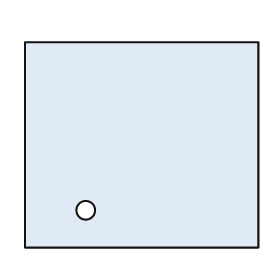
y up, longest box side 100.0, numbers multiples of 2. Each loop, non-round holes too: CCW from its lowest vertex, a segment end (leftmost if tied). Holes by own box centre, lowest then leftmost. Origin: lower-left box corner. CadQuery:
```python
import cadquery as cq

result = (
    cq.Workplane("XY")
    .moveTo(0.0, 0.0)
    .lineTo(100.0, 0.0)
    .lineTo(100.0, 88.0)
    .lineTo(0.0, 88.0)
    .close()
    .moveTo(26.0, 16.0)
    .circle(4.0)
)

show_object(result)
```